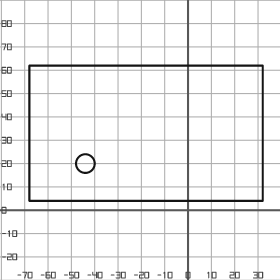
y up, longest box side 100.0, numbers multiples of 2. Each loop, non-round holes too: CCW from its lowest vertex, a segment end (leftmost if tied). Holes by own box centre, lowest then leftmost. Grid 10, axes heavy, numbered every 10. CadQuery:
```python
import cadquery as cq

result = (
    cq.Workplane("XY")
    .moveTo(-68.0, 4.0)
    .lineTo(32.0, 4.0)
    .lineTo(32.0, 62.0)
    .lineTo(-68.0, 62.0)
    .close()
    .moveTo(-44.0, 20.0)
    .circle(4.0)
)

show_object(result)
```